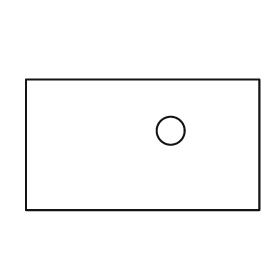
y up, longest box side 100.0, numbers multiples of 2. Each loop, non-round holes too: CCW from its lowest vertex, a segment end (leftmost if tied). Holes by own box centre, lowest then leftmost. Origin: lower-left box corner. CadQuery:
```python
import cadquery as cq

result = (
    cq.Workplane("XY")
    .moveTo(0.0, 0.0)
    .lineTo(100.0, 0.0)
    .lineTo(100.0, 56.0)
    .lineTo(0.0, 56.0)
    .close()
    .moveTo(62.0, 34.0)
    .circle(6.0)
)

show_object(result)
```